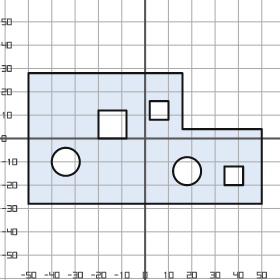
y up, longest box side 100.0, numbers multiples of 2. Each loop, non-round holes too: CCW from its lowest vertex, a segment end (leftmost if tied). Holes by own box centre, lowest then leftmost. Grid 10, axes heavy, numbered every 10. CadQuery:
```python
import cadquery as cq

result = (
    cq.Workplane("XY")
    .moveTo(-50.0, -28.0)
    .lineTo(50.0, -28.0)
    .lineTo(50.0, 4.0)
    .lineTo(16.0, 4.0)
    .lineTo(16.0, 28.0)
    .lineTo(-50.0, 28.0)
    .close()
    .moveTo(34.0, -20.0)
    .lineTo(42.0, -20.0)
    .lineTo(42.0, -12.0)
    .lineTo(34.0, -12.0)
    .close()
    .moveTo(18.0, -14.0)
    .circle(6.0)
    .moveTo(-34.0, -10.0)
    .circle(6.0)
    .moveTo(-20.0, 0.0)
    .lineTo(-8.0, 0.0)
    .lineTo(-8.0, 12.0)
    .lineTo(-20.0, 12.0)
    .close()
    .moveTo(2.0, 8.0)
    .lineTo(10.0, 8.0)
    .lineTo(10.0, 16.0)
    .lineTo(2.0, 16.0)
    .close()
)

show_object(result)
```